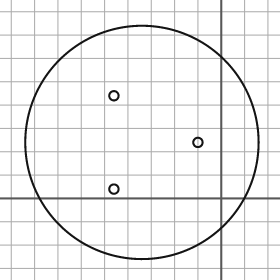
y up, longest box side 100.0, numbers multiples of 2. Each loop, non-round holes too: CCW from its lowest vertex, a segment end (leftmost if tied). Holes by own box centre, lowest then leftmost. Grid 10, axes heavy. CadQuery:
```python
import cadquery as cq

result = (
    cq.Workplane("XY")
    .moveTo(-34.0, 24.0)
    .circle(50.0)
    .moveTo(-46.0, 4.0)
    .circle(2.0)
    .moveTo(-10.0, 24.0)
    .circle(2.0)
    .moveTo(-46.0, 44.0)
    .circle(2.0)
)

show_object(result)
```